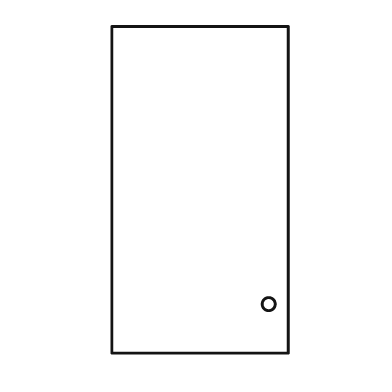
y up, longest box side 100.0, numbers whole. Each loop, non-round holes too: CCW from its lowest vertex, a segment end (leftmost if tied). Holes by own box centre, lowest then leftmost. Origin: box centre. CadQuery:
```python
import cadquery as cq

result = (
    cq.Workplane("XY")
    .moveTo(-27.0, -50.0)
    .lineTo(27.0, -50.0)
    .lineTo(27.0, 50.0)
    .lineTo(-27.0, 50.0)
    .close()
    .moveTo(21.0, -35.0)
    .circle(2.0)
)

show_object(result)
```